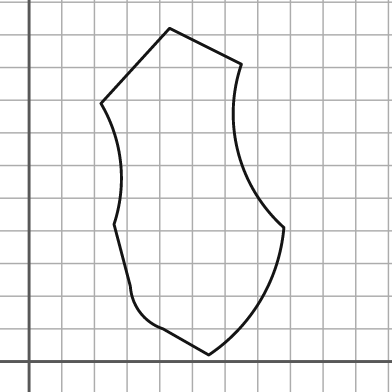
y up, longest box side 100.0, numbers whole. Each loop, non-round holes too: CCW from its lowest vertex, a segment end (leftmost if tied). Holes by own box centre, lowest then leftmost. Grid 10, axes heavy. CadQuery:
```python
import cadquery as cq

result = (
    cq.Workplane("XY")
    .moveTo(55.0, 2.0)
    .threePointArc((71.0, 19.0), (78.0, 41.0))
    .threePointArc((64.0, 64.0), (65.0, 91.0))
    .lineTo(43.0, 102.0)
    .lineTo(22.0, 79.0)
    .threePointArc((28.0, 61.0), (26.0, 42.0))
    .lineTo(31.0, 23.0)
    .threePointArc((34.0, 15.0), (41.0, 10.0))
    .close()
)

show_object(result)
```